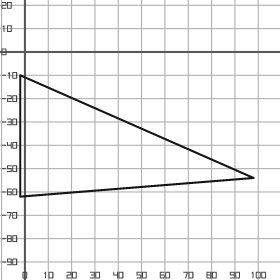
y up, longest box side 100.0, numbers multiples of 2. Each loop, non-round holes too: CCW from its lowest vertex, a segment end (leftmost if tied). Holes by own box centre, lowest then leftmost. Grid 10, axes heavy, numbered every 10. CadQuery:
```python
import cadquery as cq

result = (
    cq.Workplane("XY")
    .moveTo(-2.0, -62.0)
    .lineTo(98.0, -54.0)
    .lineTo(-2.0, -10.0)
    .close()
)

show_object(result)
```